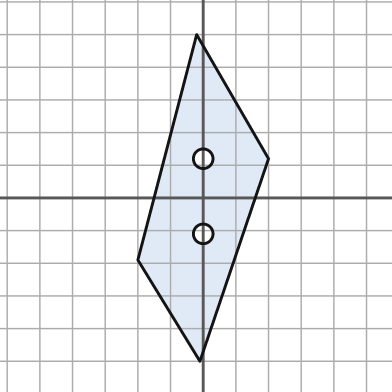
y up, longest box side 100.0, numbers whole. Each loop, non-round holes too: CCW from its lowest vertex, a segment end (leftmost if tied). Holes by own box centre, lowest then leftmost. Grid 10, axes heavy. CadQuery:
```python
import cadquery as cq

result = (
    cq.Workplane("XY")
    .moveTo(-1.0, -50.0)
    .lineTo(20.0, 12.0)
    .lineTo(-2.0, 50.0)
    .lineTo(-20.0, -19.0)
    .close()
    .moveTo(0.0, -11.0)
    .circle(3.0)
    .moveTo(0.0, 12.0)
    .circle(3.0)
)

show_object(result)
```